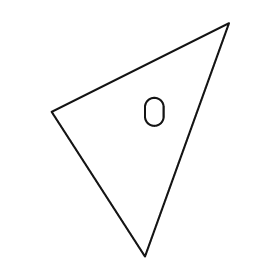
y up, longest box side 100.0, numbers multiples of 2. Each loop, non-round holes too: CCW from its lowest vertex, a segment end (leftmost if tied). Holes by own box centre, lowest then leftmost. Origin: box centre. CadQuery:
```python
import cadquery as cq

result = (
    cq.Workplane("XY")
    .moveTo(2.0, -50.0)
    .lineTo(38.0, 50.0)
    .lineTo(-38.0, 12.0)
    .close()
    .moveTo(2.0, 10.0)
    .threePointArc((6.0, 6.0), (10.0, 10.0))
    .lineTo(10.0, 14.0)
    .threePointArc((6.0, 18.0), (2.0, 14.0))
    .close()
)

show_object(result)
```